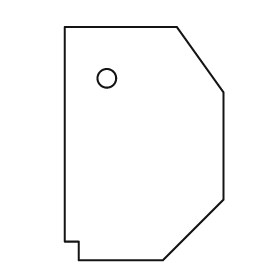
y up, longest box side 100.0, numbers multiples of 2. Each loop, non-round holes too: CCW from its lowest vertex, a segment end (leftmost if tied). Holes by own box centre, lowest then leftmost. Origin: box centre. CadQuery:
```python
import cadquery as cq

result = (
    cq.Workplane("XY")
    .moveTo(-28.0, -50.0)
    .lineTo(8.0, -50.0)
    .lineTo(34.0, -24.0)
    .lineTo(34.0, 22.0)
    .lineTo(14.0, 50.0)
    .lineTo(-34.0, 50.0)
    .lineTo(-34.0, -42.0)
    .lineTo(-28.0, -42.0)
    .close()
    .moveTo(-16.0, 28.0)
    .circle(4.0)
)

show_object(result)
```